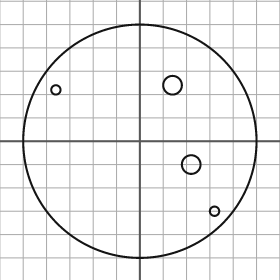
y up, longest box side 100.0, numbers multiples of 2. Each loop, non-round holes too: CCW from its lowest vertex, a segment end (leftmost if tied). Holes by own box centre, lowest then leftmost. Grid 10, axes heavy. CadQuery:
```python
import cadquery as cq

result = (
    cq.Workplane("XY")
    .moveTo(0.0, 0.0)
    .circle(50.0)
    .moveTo(32.0, -30.0)
    .circle(2.0)
    .moveTo(22.0, -10.0)
    .circle(4.0)
    .moveTo(-36.0, 22.0)
    .circle(2.0)
    .moveTo(14.0, 24.0)
    .circle(4.0)
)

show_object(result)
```